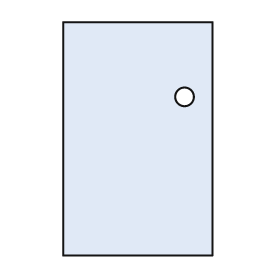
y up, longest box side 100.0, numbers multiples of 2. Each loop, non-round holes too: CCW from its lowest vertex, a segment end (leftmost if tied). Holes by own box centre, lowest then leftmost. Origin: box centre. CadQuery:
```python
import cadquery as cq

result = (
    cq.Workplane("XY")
    .moveTo(-32.0, -50.0)
    .lineTo(32.0, -50.0)
    .lineTo(32.0, 50.0)
    .lineTo(-32.0, 50.0)
    .close()
    .moveTo(20.0, 18.0)
    .circle(4.0)
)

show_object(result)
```